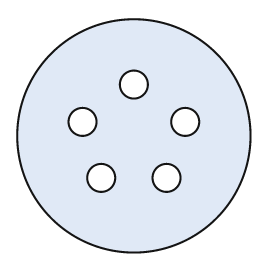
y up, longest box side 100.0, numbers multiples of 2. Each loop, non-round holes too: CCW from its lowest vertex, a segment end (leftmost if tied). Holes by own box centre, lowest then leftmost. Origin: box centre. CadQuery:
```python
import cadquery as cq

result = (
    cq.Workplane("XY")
    .moveTo(0.0, 0.0)
    .circle(50.0)
    .moveTo(-14.0, -18.0)
    .circle(6.0)
    .moveTo(14.0, -18.0)
    .circle(6.0)
    .moveTo(-22.0, 6.0)
    .circle(6.0)
    .moveTo(22.0, 6.0)
    .circle(6.0)
    .moveTo(0.0, 22.0)
    .circle(6.0)
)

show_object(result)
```